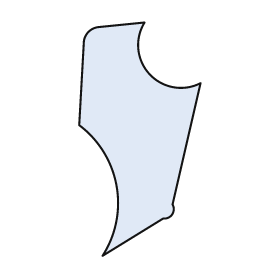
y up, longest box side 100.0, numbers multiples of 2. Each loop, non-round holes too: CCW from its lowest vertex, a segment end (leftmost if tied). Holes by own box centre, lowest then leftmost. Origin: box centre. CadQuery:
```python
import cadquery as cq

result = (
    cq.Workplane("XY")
    .moveTo(-16.0, -50.0)
    .lineTo(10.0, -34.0)
    .threePointArc((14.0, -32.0), (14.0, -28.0))
    .lineTo(26.0, 24.0)
    .threePointArc((4.0, 28.0), (2.0, 50.0))
    .lineTo(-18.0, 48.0)
    .threePointArc((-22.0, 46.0), (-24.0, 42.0))
    .lineTo(-26.0, 6.0)
    .threePointArc((-10.0, -20.0), (-16.0, -50.0))
    .close()
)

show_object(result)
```